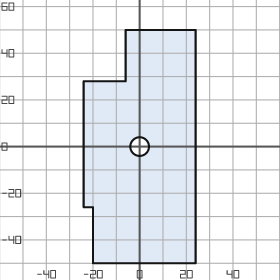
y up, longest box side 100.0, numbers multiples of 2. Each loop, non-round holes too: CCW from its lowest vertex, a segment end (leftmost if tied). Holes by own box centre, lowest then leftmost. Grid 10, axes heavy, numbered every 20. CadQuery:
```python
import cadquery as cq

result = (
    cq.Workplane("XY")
    .moveTo(-20.0, -50.0)
    .lineTo(24.0, -50.0)
    .lineTo(24.0, 50.0)
    .lineTo(-6.0, 50.0)
    .lineTo(-6.0, 28.0)
    .lineTo(-24.0, 28.0)
    .lineTo(-24.0, -26.0)
    .lineTo(-20.0, -26.0)
    .close()
    .moveTo(0.0, 0.0)
    .circle(4.0)
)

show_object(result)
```